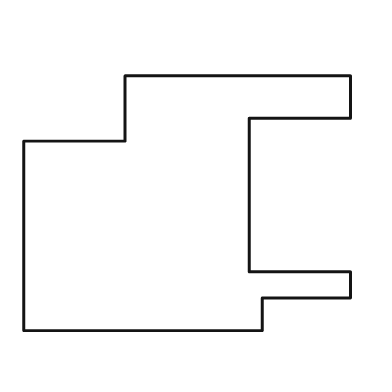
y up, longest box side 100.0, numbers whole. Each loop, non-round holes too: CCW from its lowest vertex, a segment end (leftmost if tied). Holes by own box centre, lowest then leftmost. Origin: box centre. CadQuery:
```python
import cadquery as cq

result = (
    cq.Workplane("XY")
    .moveTo(-50.0, -39.0)
    .lineTo(23.0, -39.0)
    .lineTo(23.0, -29.0)
    .lineTo(50.0, -29.0)
    .lineTo(50.0, -21.0)
    .lineTo(19.0, -21.0)
    .lineTo(19.0, 26.0)
    .lineTo(50.0, 26.0)
    .lineTo(50.0, 39.0)
    .lineTo(-19.0, 39.0)
    .lineTo(-19.0, 19.0)
    .lineTo(-50.0, 19.0)
    .close()
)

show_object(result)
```